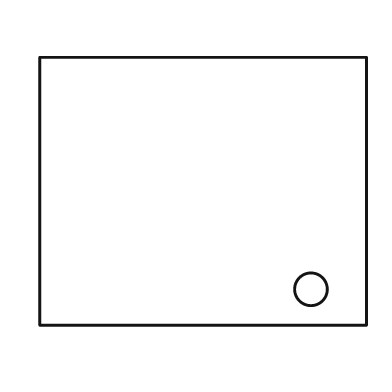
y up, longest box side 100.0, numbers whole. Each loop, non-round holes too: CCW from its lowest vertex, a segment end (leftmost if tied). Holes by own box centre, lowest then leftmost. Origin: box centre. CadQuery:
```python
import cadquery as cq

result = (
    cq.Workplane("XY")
    .moveTo(-50.0, -41.0)
    .lineTo(50.0, -41.0)
    .lineTo(50.0, 41.0)
    .lineTo(-50.0, 41.0)
    .close()
    .moveTo(33.0, -30.0)
    .circle(5.0)
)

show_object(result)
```